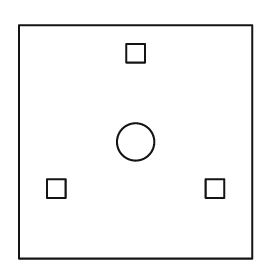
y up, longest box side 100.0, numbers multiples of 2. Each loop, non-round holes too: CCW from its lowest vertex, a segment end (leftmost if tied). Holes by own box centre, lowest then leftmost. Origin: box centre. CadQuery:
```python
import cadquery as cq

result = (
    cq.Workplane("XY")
    .moveTo(-50.0, -50.0)
    .lineTo(50.0, -50.0)
    .lineTo(50.0, 50.0)
    .lineTo(-50.0, 50.0)
    .close()
    .moveTo(-38.0, -24.0)
    .lineTo(-30.0, -24.0)
    .lineTo(-30.0, -16.0)
    .lineTo(-38.0, -16.0)
    .close()
    .moveTo(30.0, -24.0)
    .lineTo(38.0, -24.0)
    .lineTo(38.0, -16.0)
    .lineTo(30.0, -16.0)
    .close()
    .moveTo(0.0, 0.0)
    .circle(8.0)
    .moveTo(-4.0, 34.0)
    .lineTo(4.0, 34.0)
    .lineTo(4.0, 42.0)
    .lineTo(-4.0, 42.0)
    .close()
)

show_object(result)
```